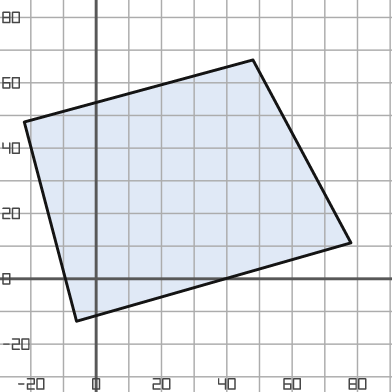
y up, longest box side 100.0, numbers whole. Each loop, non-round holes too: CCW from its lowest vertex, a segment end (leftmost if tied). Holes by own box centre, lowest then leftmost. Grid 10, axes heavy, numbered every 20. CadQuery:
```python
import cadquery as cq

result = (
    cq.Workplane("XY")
    .moveTo(-6.0, -13.0)
    .lineTo(78.0, 11.0)
    .lineTo(48.0, 67.0)
    .lineTo(-22.0, 48.0)
    .close()
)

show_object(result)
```